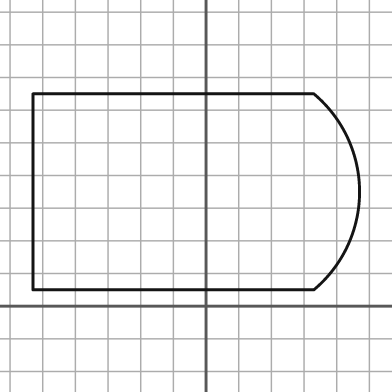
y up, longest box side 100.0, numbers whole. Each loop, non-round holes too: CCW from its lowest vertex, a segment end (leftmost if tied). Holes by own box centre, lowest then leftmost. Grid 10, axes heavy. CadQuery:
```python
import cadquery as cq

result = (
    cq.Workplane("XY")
    .moveTo(-53.0, 5.0)
    .lineTo(33.0, 5.0)
    .threePointArc((47.0, 35.0), (33.0, 65.0))
    .lineTo(-53.0, 65.0)
    .close()
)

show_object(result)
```